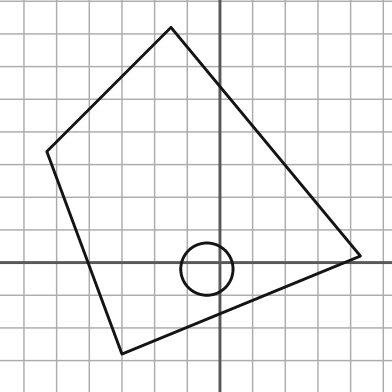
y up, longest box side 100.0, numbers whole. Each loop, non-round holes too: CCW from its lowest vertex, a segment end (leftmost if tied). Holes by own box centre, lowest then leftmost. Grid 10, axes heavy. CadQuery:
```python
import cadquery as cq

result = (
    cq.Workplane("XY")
    .moveTo(-30.0, -28.0)
    .lineTo(43.0, 2.0)
    .lineTo(-15.0, 72.0)
    .lineTo(-53.0, 34.0)
    .close()
    .moveTo(-4.0, -2.0)
    .circle(8.0)
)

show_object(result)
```